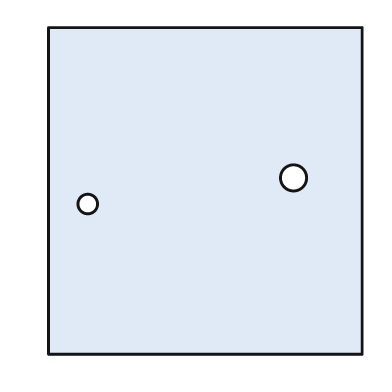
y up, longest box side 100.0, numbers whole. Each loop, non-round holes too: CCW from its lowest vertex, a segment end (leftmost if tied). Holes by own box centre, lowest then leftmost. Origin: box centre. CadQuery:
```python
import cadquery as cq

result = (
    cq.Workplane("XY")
    .moveTo(-48.0, -50.0)
    .lineTo(48.0, -50.0)
    .lineTo(48.0, 50.0)
    .lineTo(-48.0, 50.0)
    .close()
    .moveTo(-36.0, -4.0)
    .circle(3.0)
    .moveTo(27.0, 4.0)
    .circle(4.0)
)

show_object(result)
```